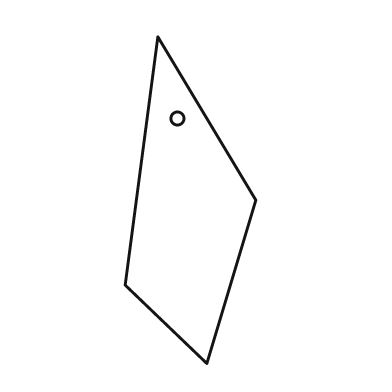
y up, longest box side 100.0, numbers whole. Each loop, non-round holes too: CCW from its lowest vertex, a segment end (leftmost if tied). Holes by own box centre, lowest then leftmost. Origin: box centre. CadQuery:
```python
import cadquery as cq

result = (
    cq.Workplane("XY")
    .moveTo(5.0, -50.0)
    .lineTo(20.0, 0.0)
    .lineTo(-10.0, 50.0)
    .lineTo(-20.0, -26.0)
    .close()
    .moveTo(-4.0, 25.0)
    .circle(2.0)
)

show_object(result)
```